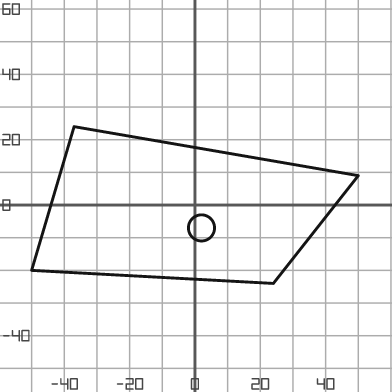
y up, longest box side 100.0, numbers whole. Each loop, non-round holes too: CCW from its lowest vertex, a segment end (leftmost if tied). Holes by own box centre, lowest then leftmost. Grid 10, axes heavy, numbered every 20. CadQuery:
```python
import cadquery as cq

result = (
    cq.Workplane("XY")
    .moveTo(24.0, -24.0)
    .lineTo(50.0, 9.0)
    .lineTo(-37.0, 24.0)
    .lineTo(-50.0, -20.0)
    .close()
    .moveTo(2.0, -7.0)
    .circle(4.0)
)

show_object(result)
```